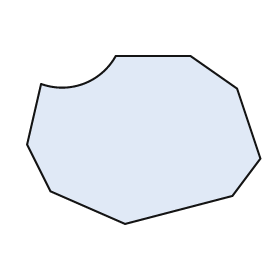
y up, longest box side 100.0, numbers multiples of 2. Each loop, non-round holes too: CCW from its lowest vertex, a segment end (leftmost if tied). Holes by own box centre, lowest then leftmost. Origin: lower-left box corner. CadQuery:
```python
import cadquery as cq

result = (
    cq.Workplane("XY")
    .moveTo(42.0, 0.0)
    .lineTo(88.0, 12.0)
    .lineTo(100.0, 28.0)
    .lineTo(90.0, 58.0)
    .lineTo(70.0, 72.0)
    .lineTo(38.0, 72.0)
    .threePointArc((24.0, 60.0), (6.0, 60.0))
    .lineTo(0.0, 34.0)
    .lineTo(10.0, 14.0)
    .close()
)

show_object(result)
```